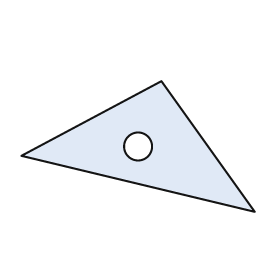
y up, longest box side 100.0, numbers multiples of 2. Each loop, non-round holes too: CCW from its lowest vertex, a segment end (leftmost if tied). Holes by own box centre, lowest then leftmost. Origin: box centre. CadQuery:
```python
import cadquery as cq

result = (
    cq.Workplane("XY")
    .moveTo(50.0, -28.0)
    .lineTo(10.0, 28.0)
    .lineTo(-50.0, -4.0)
    .close()
    .moveTo(0.0, 0.0)
    .circle(6.0)
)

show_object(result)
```